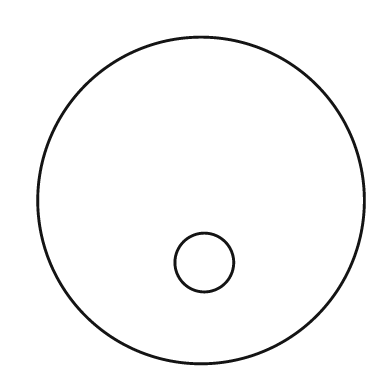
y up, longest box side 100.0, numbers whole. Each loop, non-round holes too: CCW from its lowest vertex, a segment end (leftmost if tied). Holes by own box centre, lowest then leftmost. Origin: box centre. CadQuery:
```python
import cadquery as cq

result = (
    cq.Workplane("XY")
    .moveTo(0.0, 0.0)
    .circle(50.0)
    .moveTo(1.0, -19.0)
    .circle(9.0)
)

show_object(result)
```